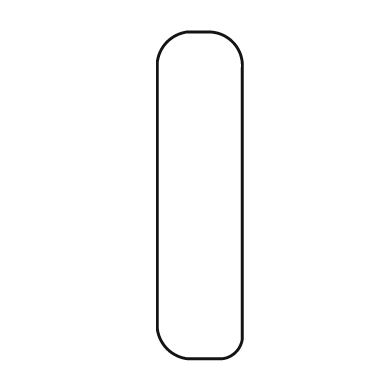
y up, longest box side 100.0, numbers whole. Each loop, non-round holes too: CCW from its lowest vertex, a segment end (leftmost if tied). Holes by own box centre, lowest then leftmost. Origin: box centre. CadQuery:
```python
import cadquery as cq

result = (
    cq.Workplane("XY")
    .moveTo(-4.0, -50.0)
    .lineTo(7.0, -50.0)
    .threePointArc((11.0, -48.0), (13.0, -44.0))
    .lineTo(13.0, 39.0)
    .threePointArc((10.0, 47.0), (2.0, 50.0))
    .lineTo(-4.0, 50.0)
    .threePointArc((-10.0, 47.0), (-13.0, 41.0))
    .lineTo(-13.0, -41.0)
    .threePointArc((-10.0, -47.0), (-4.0, -50.0))
    .close()
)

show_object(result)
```